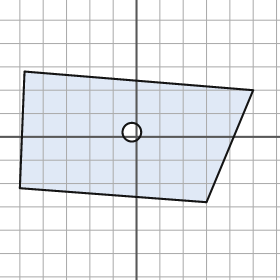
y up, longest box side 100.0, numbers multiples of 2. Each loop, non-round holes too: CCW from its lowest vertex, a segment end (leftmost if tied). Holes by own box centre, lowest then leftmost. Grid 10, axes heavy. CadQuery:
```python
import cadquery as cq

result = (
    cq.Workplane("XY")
    .moveTo(30.0, -28.0)
    .lineTo(50.0, 20.0)
    .lineTo(-48.0, 28.0)
    .lineTo(-50.0, -22.0)
    .close()
    .moveTo(-2.0, 2.0)
    .circle(4.0)
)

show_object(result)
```